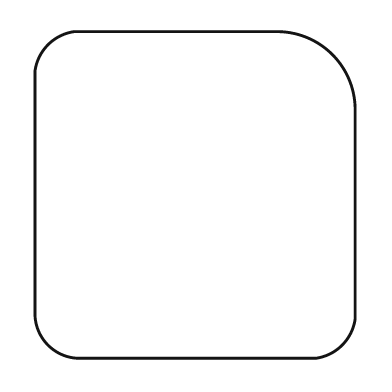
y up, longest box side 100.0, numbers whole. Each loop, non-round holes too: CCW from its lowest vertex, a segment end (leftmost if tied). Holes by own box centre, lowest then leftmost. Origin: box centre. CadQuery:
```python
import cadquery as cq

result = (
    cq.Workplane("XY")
    .moveTo(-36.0, -50.0)
    .lineTo(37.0, -50.0)
    .threePointArc((45.0, -46.0), (49.0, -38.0))
    .lineTo(49.0, 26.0)
    .threePointArc((42.0, 43.0), (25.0, 50.0))
    .lineTo(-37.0, 50.0)
    .threePointArc((-45.0, 46.0), (-49.0, 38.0))
    .lineTo(-49.0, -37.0)
    .threePointArc((-45.0, -46.0), (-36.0, -50.0))
    .close()
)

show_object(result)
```